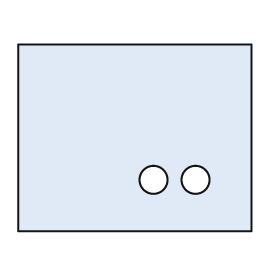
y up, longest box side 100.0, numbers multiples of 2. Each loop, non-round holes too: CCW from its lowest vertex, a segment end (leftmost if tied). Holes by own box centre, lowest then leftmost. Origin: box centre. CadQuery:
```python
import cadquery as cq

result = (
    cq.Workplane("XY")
    .moveTo(-50.0, -40.0)
    .lineTo(50.0, -40.0)
    .lineTo(50.0, 40.0)
    .lineTo(-50.0, 40.0)
    .close()
    .moveTo(8.0, -18.0)
    .circle(6.0)
    .moveTo(26.0, -18.0)
    .circle(6.0)
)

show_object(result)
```